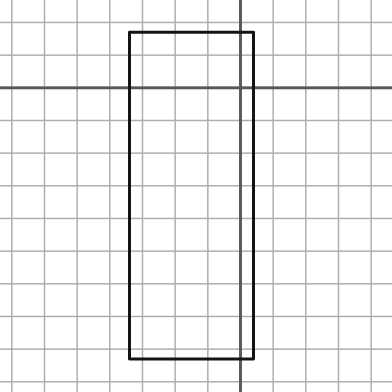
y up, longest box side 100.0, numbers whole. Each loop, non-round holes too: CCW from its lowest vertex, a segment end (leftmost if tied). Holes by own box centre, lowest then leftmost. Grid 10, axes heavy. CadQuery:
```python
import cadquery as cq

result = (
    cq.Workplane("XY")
    .moveTo(-34.0, -83.0)
    .lineTo(4.0, -83.0)
    .lineTo(4.0, 17.0)
    .lineTo(-34.0, 17.0)
    .close()
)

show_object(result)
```